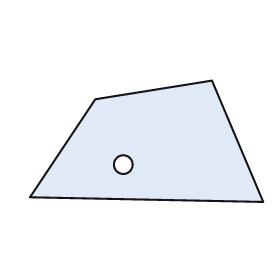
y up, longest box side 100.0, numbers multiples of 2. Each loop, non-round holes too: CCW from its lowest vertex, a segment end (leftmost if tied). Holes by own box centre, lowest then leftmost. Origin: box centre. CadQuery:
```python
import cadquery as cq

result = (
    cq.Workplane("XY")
    .moveTo(50.0, -26.0)
    .lineTo(28.0, 26.0)
    .lineTo(-22.0, 18.0)
    .lineTo(-50.0, -24.0)
    .close()
    .moveTo(-10.0, -10.0)
    .circle(4.0)
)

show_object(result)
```